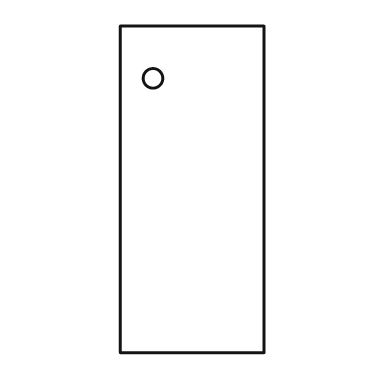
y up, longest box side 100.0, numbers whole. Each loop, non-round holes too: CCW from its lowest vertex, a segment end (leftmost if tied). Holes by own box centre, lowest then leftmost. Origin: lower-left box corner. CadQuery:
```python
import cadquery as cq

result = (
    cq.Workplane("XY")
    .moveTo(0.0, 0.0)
    .lineTo(44.0, 0.0)
    .lineTo(44.0, 100.0)
    .lineTo(0.0, 100.0)
    .close()
    .moveTo(10.0, 84.0)
    .circle(3.0)
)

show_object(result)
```